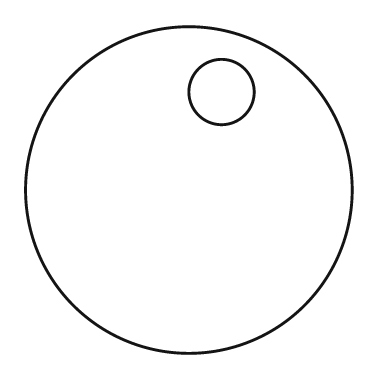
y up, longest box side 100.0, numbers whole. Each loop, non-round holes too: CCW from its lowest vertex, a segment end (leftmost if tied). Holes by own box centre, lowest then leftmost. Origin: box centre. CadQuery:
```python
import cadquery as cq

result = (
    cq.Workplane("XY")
    .moveTo(0.0, 0.0)
    .circle(50.0)
    .moveTo(10.0, 30.0)
    .circle(10.0)
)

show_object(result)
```